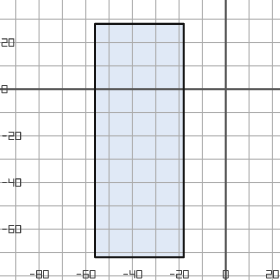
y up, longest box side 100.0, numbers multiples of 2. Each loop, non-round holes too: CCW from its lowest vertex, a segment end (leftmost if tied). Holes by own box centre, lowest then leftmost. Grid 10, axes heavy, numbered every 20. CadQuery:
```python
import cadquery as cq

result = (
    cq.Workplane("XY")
    .moveTo(-56.0, -72.0)
    .lineTo(-18.0, -72.0)
    .lineTo(-18.0, 28.0)
    .lineTo(-56.0, 28.0)
    .close()
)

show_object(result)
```